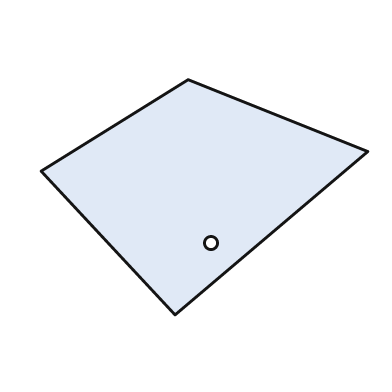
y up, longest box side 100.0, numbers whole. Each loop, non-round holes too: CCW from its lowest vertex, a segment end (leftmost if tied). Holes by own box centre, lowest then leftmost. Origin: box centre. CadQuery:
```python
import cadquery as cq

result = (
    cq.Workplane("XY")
    .moveTo(-9.0, -36.0)
    .lineTo(50.0, 14.0)
    .lineTo(-5.0, 36.0)
    .lineTo(-50.0, 8.0)
    .close()
    .moveTo(2.0, -14.0)
    .circle(2.0)
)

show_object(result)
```